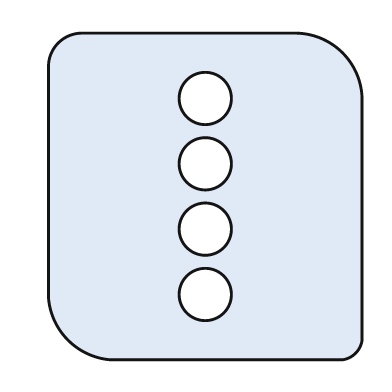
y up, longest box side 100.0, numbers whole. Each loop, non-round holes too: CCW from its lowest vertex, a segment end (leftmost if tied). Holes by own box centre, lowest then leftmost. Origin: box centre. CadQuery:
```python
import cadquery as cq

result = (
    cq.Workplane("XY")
    .moveTo(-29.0, -50.0)
    .lineTo(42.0, -50.0)
    .threePointArc((46.0, -48.0), (48.0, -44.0))
    .lineTo(48.0, 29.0)
    .threePointArc((42.0, 44.0), (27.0, 50.0))
    .lineTo(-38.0, 50.0)
    .threePointArc((-45.0, 47.0), (-48.0, 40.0))
    .lineTo(-48.0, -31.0)
    .threePointArc((-42.0, -44.0), (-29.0, -50.0))
    .close()
    .moveTo(0.0, -30.0)
    .circle(8.0)
    .moveTo(0.0, -10.0)
    .circle(8.0)
    .moveTo(0.0, 10.0)
    .circle(8.0)
    .moveTo(0.0, 30.0)
    .circle(8.0)
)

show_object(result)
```